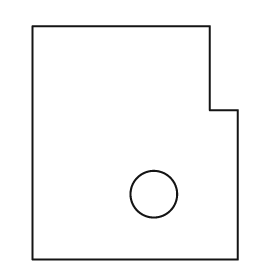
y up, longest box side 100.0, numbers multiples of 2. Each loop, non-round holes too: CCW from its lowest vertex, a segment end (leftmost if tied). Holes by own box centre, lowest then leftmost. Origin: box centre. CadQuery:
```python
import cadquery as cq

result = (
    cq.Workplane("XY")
    .moveTo(-44.0, -50.0)
    .lineTo(44.0, -50.0)
    .lineTo(44.0, 14.0)
    .lineTo(32.0, 14.0)
    .lineTo(32.0, 50.0)
    .lineTo(-44.0, 50.0)
    .close()
    .moveTo(8.0, -22.0)
    .circle(10.0)
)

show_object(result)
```